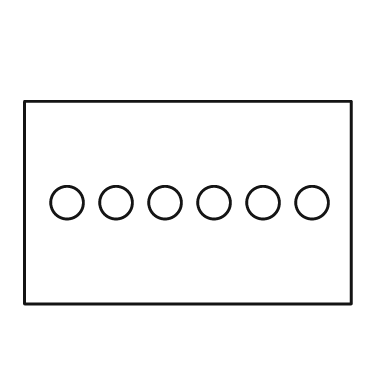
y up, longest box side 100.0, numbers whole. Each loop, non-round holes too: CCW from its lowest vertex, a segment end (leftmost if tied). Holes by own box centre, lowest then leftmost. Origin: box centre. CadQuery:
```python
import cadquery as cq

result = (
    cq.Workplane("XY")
    .moveTo(-50.0, -31.0)
    .lineTo(50.0, -31.0)
    .lineTo(50.0, 31.0)
    .lineTo(-50.0, 31.0)
    .close()
    .moveTo(-37.0, 0.0)
    .circle(5.0)
    .moveTo(-22.0, 0.0)
    .circle(5.0)
    .moveTo(-7.0, 0.0)
    .circle(5.0)
    .moveTo(8.0, 0.0)
    .circle(5.0)
    .moveTo(23.0, 0.0)
    .circle(5.0)
    .moveTo(38.0, 0.0)
    .circle(5.0)
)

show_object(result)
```